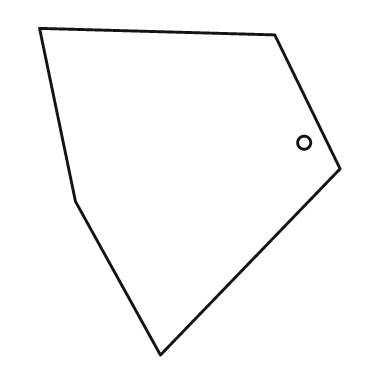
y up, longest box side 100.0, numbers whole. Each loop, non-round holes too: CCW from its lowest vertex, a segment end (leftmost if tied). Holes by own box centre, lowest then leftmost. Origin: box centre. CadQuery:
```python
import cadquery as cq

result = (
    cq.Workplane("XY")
    .moveTo(-9.0, -50.0)
    .lineTo(46.0, 7.0)
    .lineTo(26.0, 48.0)
    .lineTo(-46.0, 50.0)
    .lineTo(-35.0, -3.0)
    .close()
    .moveTo(35.0, 15.0)
    .circle(2.0)
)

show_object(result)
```